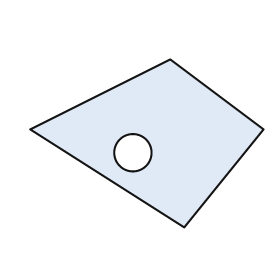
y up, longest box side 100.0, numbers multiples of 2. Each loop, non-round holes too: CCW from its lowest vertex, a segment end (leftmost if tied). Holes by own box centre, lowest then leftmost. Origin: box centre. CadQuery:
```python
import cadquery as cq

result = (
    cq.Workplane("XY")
    .moveTo(16.0, -36.0)
    .lineTo(50.0, 6.0)
    .lineTo(10.0, 36.0)
    .lineTo(-50.0, 6.0)
    .close()
    .moveTo(-6.0, -4.0)
    .circle(8.0)
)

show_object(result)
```